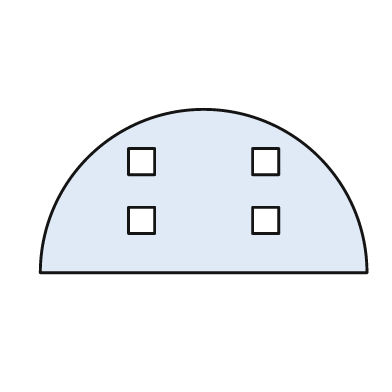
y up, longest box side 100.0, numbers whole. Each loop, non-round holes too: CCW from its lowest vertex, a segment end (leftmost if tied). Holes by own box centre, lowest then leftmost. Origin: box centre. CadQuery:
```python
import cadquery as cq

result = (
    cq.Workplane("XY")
    .moveTo(-50.0, -25.0)
    .lineTo(50.0, -25.0)
    .threePointArc((0.0, 25.0), (-50.0, -25.0))
    .close()
    .moveTo(-23.0, -13.0)
    .lineTo(-15.0, -13.0)
    .lineTo(-15.0, -5.0)
    .lineTo(-23.0, -5.0)
    .close()
    .moveTo(15.0, -13.0)
    .lineTo(23.0, -13.0)
    .lineTo(23.0, -5.0)
    .lineTo(15.0, -5.0)
    .close()
    .moveTo(-23.0, 5.0)
    .lineTo(-15.0, 5.0)
    .lineTo(-15.0, 13.0)
    .lineTo(-23.0, 13.0)
    .close()
    .moveTo(15.0, 5.0)
    .lineTo(23.0, 5.0)
    .lineTo(23.0, 13.0)
    .lineTo(15.0, 13.0)
    .close()
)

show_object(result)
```